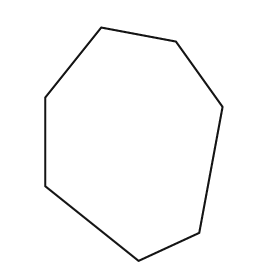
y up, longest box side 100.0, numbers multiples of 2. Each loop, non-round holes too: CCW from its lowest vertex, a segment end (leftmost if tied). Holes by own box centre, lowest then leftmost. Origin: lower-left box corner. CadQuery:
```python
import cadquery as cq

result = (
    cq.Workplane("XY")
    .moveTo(40.0, 0.0)
    .lineTo(66.0, 12.0)
    .lineTo(76.0, 66.0)
    .lineTo(56.0, 94.0)
    .lineTo(24.0, 100.0)
    .lineTo(0.0, 70.0)
    .lineTo(0.0, 32.0)
    .close()
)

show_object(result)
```